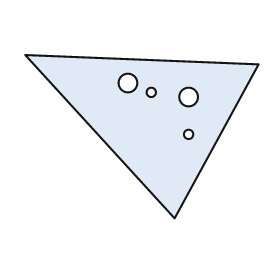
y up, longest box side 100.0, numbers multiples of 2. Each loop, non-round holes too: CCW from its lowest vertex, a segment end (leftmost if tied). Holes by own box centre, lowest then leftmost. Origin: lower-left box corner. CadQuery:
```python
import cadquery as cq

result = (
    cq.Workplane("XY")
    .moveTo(64.0, 0.0)
    .lineTo(100.0, 66.0)
    .lineTo(0.0, 70.0)
    .close()
    .moveTo(70.0, 36.0)
    .circle(2.0)
    .moveTo(70.0, 52.0)
    .circle(4.0)
    .moveTo(54.0, 54.0)
    .circle(2.0)
    .moveTo(44.0, 58.0)
    .circle(4.0)
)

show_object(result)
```